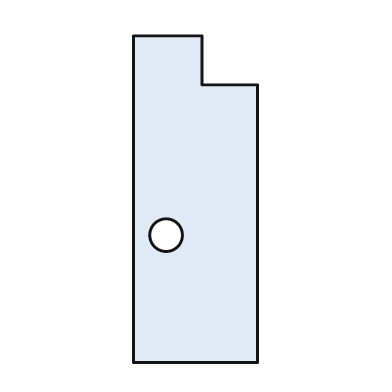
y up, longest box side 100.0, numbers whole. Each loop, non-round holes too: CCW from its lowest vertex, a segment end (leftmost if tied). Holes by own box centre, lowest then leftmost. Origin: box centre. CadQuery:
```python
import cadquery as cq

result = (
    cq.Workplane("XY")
    .moveTo(-19.0, -50.0)
    .lineTo(19.0, -50.0)
    .lineTo(19.0, 35.0)
    .lineTo(2.0, 35.0)
    .lineTo(2.0, 50.0)
    .lineTo(-19.0, 50.0)
    .close()
    .moveTo(-9.0, -11.0)
    .circle(5.0)
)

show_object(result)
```